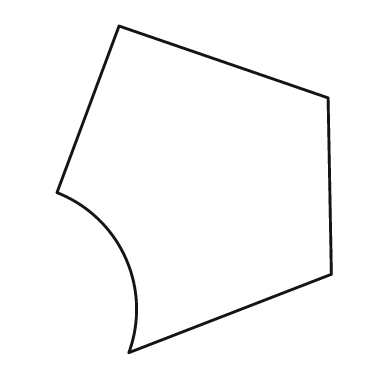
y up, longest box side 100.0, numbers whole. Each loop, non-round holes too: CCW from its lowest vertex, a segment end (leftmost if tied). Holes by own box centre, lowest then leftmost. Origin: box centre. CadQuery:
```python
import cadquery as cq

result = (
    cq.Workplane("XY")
    .moveTo(-20.0, -50.0)
    .lineTo(42.0, -26.0)
    .lineTo(41.0, 28.0)
    .lineTo(-23.0, 50.0)
    .lineTo(-42.0, -1.0)
    .threePointArc((-21.0, -21.0), (-20.0, -50.0))
    .close()
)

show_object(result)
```